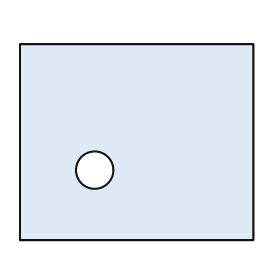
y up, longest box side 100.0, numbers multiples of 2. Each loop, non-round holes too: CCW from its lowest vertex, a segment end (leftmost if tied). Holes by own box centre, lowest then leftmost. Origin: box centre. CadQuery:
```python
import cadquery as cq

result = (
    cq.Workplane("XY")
    .moveTo(-50.0, -42.0)
    .lineTo(50.0, -42.0)
    .lineTo(50.0, 42.0)
    .lineTo(-50.0, 42.0)
    .close()
    .moveTo(-18.0, -12.0)
    .circle(8.0)
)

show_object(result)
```